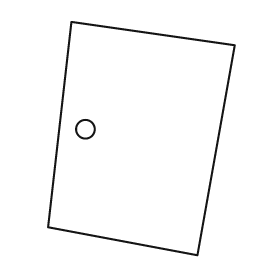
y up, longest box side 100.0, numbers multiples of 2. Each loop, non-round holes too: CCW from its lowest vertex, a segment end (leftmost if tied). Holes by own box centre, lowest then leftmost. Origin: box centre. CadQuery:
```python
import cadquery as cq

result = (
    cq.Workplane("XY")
    .moveTo(24.0, -50.0)
    .lineTo(40.0, 40.0)
    .lineTo(-30.0, 50.0)
    .lineTo(-40.0, -38.0)
    .close()
    .moveTo(-24.0, 4.0)
    .circle(4.0)
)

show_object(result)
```